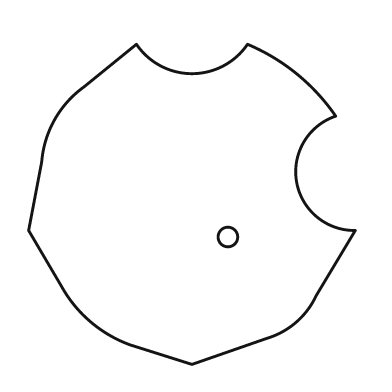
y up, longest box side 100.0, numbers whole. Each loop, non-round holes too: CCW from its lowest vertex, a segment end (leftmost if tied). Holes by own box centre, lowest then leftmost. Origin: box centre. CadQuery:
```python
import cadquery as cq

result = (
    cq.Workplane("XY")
    .moveTo(0.0, -49.0)
    .lineTo(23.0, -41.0)
    .threePointArc((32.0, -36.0), (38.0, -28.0))
    .lineTo(50.0, -8.0)
    .threePointArc((32.0, 7.0), (44.0, 27.0))
    .threePointArc((32.0, 40.0), (17.0, 49.0))
    .threePointArc((0.0, 40.0), (-17.0, 49.0))
    .lineTo(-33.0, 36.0)
    .threePointArc((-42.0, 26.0), (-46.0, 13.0))
    .lineTo(-50.0, -8.0)
    .lineTo(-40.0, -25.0)
    .threePointArc((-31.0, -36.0), (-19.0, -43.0))
    .close()
    .moveTo(11.0, -10.0)
    .circle(3.0)
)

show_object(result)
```